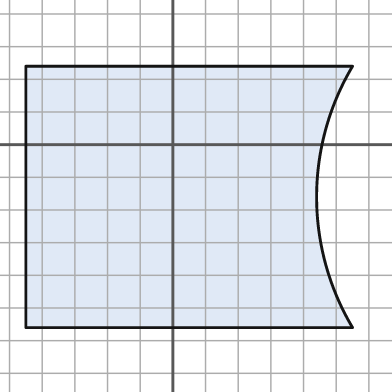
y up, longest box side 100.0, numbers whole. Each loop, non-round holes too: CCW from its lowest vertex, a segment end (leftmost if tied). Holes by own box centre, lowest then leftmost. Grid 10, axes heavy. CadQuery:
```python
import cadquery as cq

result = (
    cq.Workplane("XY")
    .moveTo(-45.0, -56.0)
    .lineTo(55.0, -56.0)
    .threePointArc((44.0, -16.0), (55.0, 24.0))
    .lineTo(-45.0, 24.0)
    .close()
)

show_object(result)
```